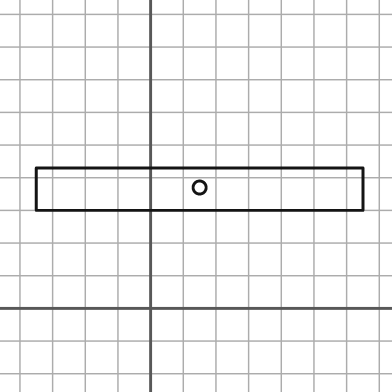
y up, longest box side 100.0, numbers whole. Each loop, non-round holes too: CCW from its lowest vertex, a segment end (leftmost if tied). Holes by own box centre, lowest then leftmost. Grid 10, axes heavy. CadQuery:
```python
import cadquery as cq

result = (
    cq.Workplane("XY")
    .moveTo(-35.0, 30.0)
    .lineTo(65.0, 30.0)
    .lineTo(65.0, 43.0)
    .lineTo(-35.0, 43.0)
    .close()
    .moveTo(15.0, 37.0)
    .circle(2.0)
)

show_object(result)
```